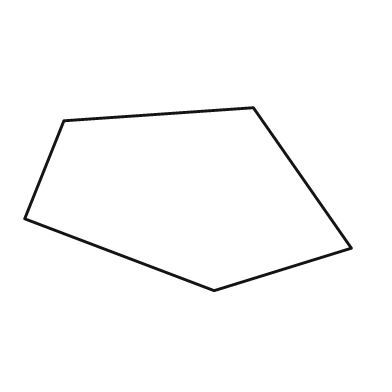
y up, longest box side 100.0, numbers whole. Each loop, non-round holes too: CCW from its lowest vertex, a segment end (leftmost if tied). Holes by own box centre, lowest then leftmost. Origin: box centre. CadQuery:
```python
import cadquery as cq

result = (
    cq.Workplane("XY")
    .moveTo(8.0, -28.0)
    .lineTo(50.0, -15.0)
    .lineTo(20.0, 28.0)
    .lineTo(-38.0, 24.0)
    .lineTo(-50.0, -6.0)
    .close()
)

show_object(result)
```